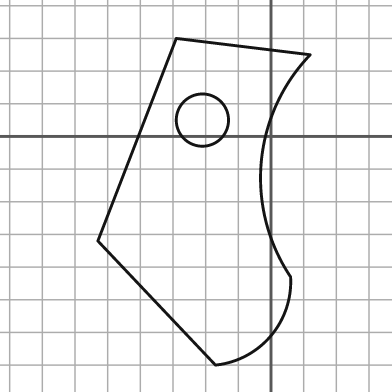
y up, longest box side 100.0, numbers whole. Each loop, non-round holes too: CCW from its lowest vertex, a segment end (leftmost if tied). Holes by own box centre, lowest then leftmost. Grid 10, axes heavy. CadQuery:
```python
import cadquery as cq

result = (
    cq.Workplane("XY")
    .moveTo(-17.0, -70.0)
    .threePointArc((0.0, -61.0), (6.0, -43.0))
    .threePointArc((-3.0, -8.0), (12.0, 25.0))
    .lineTo(-29.0, 30.0)
    .lineTo(-53.0, -32.0)
    .close()
    .moveTo(-21.0, 5.0)
    .circle(8.0)
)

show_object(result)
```